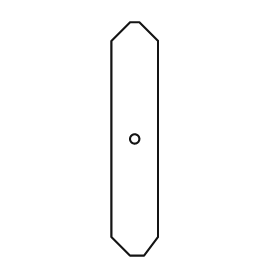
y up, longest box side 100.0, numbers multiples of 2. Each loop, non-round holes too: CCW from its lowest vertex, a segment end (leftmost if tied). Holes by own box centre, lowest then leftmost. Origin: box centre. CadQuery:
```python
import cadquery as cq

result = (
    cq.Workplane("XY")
    .moveTo(-2.0, -50.0)
    .lineTo(4.0, -50.0)
    .lineTo(10.0, -42.0)
    .lineTo(10.0, 42.0)
    .lineTo(2.0, 50.0)
    .lineTo(-2.0, 50.0)
    .lineTo(-10.0, 42.0)
    .lineTo(-10.0, -42.0)
    .close()
    .moveTo(0.0, 0.0)
    .circle(2.0)
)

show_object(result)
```